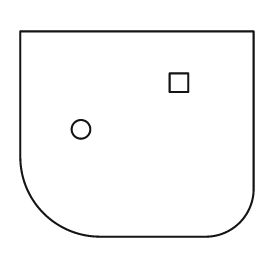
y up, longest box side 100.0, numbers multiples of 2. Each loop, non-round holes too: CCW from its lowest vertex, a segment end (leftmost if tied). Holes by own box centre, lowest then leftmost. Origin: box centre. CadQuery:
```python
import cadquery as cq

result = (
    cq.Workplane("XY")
    .moveTo(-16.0, -44.0)
    .lineTo(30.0, -44.0)
    .threePointArc((44.0, -38.0), (50.0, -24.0))
    .lineTo(50.0, 44.0)
    .lineTo(-50.0, 44.0)
    .lineTo(-50.0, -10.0)
    .threePointArc((-40.0, -34.0), (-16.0, -44.0))
    .close()
    .moveTo(-24.0, 2.0)
    .circle(4.0)
    .moveTo(14.0, 18.0)
    .lineTo(22.0, 18.0)
    .lineTo(22.0, 26.0)
    .lineTo(14.0, 26.0)
    .close()
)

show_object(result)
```